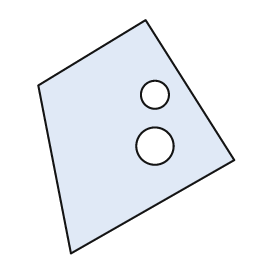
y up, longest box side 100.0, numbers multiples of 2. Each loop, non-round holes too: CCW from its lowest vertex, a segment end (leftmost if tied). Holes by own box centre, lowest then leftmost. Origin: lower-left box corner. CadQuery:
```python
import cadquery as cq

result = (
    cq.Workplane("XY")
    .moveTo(14.0, 0.0)
    .lineTo(84.0, 40.0)
    .lineTo(46.0, 100.0)
    .lineTo(0.0, 72.0)
    .close()
    .moveTo(50.0, 46.0)
    .circle(8.0)
    .moveTo(50.0, 68.0)
    .circle(6.0)
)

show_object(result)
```